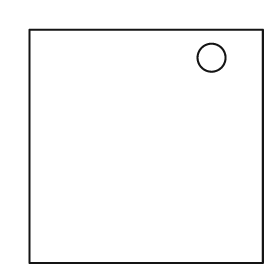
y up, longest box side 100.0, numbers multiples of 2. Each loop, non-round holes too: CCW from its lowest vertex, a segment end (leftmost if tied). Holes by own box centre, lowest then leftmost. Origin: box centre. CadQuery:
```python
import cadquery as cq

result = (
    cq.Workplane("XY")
    .moveTo(-50.0, -50.0)
    .lineTo(50.0, -50.0)
    .lineTo(50.0, 50.0)
    .lineTo(-50.0, 50.0)
    .close()
    .moveTo(28.0, 38.0)
    .circle(6.0)
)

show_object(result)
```